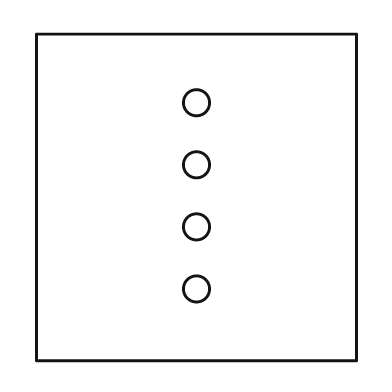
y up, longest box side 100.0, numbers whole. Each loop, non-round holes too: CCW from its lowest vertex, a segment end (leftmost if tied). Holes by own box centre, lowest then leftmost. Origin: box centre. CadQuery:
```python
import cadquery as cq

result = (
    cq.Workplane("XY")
    .moveTo(-49.0, -50.0)
    .lineTo(49.0, -50.0)
    .lineTo(49.0, 50.0)
    .lineTo(-49.0, 50.0)
    .close()
    .moveTo(0.0, -28.0)
    .circle(4.0)
    .moveTo(0.0, -9.0)
    .circle(4.0)
    .moveTo(0.0, 10.0)
    .circle(4.0)
    .moveTo(0.0, 29.0)
    .circle(4.0)
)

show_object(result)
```